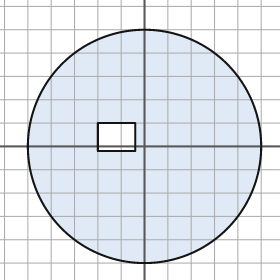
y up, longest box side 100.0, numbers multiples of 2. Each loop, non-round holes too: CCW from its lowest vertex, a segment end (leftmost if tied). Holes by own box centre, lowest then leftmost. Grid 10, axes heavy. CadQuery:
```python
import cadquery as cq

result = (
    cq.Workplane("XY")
    .moveTo(0.0, 0.0)
    .circle(50.0)
    .moveTo(-20.0, -2.0)
    .lineTo(-4.0, -2.0)
    .lineTo(-4.0, 10.0)
    .lineTo(-20.0, 10.0)
    .close()
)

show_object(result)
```